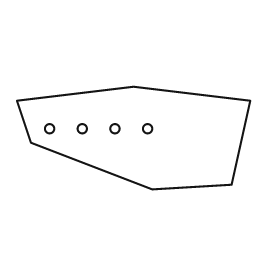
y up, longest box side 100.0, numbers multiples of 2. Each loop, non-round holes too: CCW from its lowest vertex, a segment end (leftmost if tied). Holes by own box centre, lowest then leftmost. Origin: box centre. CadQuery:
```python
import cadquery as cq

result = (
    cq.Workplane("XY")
    .moveTo(8.0, -22.0)
    .lineTo(42.0, -20.0)
    .lineTo(50.0, 16.0)
    .lineTo(0.0, 22.0)
    .lineTo(-50.0, 16.0)
    .lineTo(-44.0, -2.0)
    .close()
    .moveTo(-36.0, 4.0)
    .circle(2.0)
    .moveTo(-22.0, 4.0)
    .circle(2.0)
    .moveTo(-8.0, 4.0)
    .circle(2.0)
    .moveTo(6.0, 4.0)
    .circle(2.0)
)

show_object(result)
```